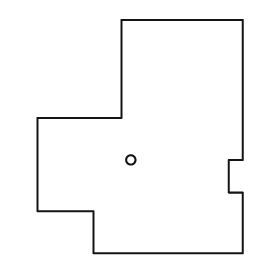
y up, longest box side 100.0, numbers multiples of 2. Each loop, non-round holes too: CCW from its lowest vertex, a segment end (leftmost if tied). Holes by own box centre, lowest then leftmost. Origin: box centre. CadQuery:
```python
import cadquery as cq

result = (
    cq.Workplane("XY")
    .moveTo(-20.0, -50.0)
    .lineTo(44.0, -50.0)
    .lineTo(44.0, -24.0)
    .lineTo(38.0, -24.0)
    .lineTo(38.0, -10.0)
    .lineTo(44.0, -10.0)
    .lineTo(44.0, 50.0)
    .lineTo(-8.0, 50.0)
    .lineTo(-8.0, 8.0)
    .lineTo(-44.0, 8.0)
    .lineTo(-44.0, -32.0)
    .lineTo(-20.0, -32.0)
    .close()
    .moveTo(-4.0, -10.0)
    .circle(2.0)
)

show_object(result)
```